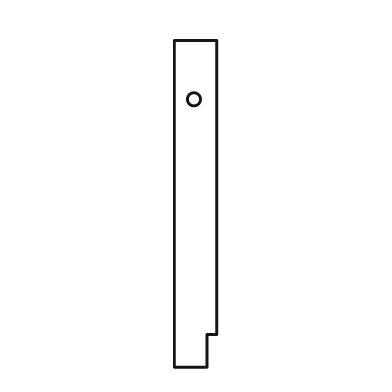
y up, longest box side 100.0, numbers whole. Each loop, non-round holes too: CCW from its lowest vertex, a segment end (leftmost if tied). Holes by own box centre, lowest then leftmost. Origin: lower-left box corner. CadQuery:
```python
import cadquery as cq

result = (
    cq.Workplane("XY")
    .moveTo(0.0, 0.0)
    .lineTo(10.0, 0.0)
    .lineTo(10.0, 10.0)
    .lineTo(13.0, 10.0)
    .lineTo(13.0, 100.0)
    .lineTo(0.0, 100.0)
    .close()
    .moveTo(6.0, 82.0)
    .circle(2.0)
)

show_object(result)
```